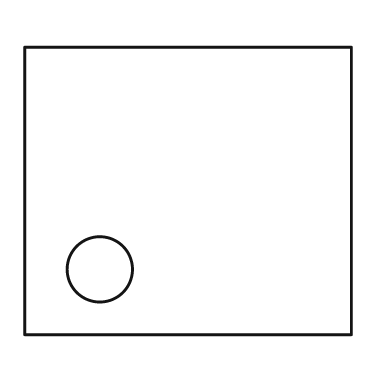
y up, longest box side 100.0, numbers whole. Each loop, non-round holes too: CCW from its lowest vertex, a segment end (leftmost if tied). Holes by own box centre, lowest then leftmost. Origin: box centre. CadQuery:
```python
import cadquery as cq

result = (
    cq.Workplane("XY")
    .moveTo(-50.0, -44.0)
    .lineTo(50.0, -44.0)
    .lineTo(50.0, 44.0)
    .lineTo(-50.0, 44.0)
    .close()
    .moveTo(-27.0, -24.0)
    .circle(10.0)
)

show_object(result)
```